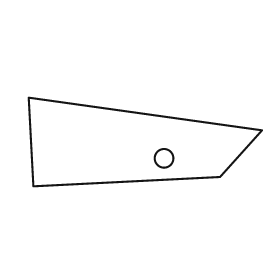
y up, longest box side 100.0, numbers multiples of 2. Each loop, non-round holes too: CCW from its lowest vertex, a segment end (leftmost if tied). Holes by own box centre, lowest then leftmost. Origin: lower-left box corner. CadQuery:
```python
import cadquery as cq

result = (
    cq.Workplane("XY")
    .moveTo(2.0, 0.0)
    .lineTo(82.0, 4.0)
    .lineTo(100.0, 24.0)
    .lineTo(0.0, 38.0)
    .close()
    .moveTo(58.0, 12.0)
    .circle(4.0)
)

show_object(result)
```